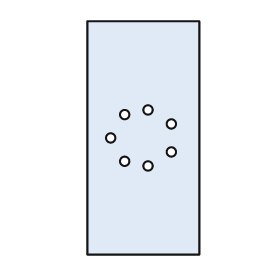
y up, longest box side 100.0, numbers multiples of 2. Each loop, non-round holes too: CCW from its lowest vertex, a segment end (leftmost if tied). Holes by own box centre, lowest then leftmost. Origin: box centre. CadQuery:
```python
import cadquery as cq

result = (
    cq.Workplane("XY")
    .moveTo(-24.0, -50.0)
    .lineTo(24.0, -50.0)
    .lineTo(24.0, 50.0)
    .lineTo(-24.0, 50.0)
    .close()
    .moveTo(2.0, -12.0)
    .circle(2.0)
    .moveTo(-8.0, -10.0)
    .circle(2.0)
    .moveTo(12.0, -6.0)
    .circle(2.0)
    .moveTo(-14.0, 0.0)
    .circle(2.0)
    .moveTo(12.0, 6.0)
    .circle(2.0)
    .moveTo(-8.0, 10.0)
    .circle(2.0)
    .moveTo(2.0, 12.0)
    .circle(2.0)
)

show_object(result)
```